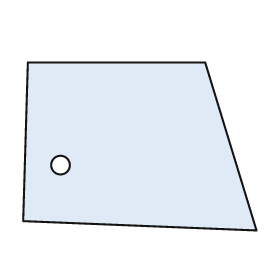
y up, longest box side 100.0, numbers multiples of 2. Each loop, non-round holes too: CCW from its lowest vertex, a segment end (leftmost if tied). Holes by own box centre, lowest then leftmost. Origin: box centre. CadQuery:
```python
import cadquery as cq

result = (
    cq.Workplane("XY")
    .moveTo(50.0, -36.0)
    .lineTo(28.0, 36.0)
    .lineTo(-48.0, 36.0)
    .lineTo(-50.0, -32.0)
    .close()
    .moveTo(-34.0, -8.0)
    .circle(4.0)
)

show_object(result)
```